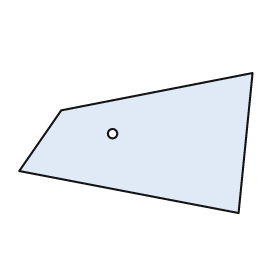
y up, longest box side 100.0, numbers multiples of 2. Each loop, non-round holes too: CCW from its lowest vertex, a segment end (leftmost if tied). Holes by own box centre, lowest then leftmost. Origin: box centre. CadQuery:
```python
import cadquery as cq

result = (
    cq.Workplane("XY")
    .moveTo(44.0, -30.0)
    .lineTo(50.0, 30.0)
    .lineTo(-32.0, 14.0)
    .lineTo(-50.0, -12.0)
    .close()
    .moveTo(-10.0, 4.0)
    .circle(2.0)
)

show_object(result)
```